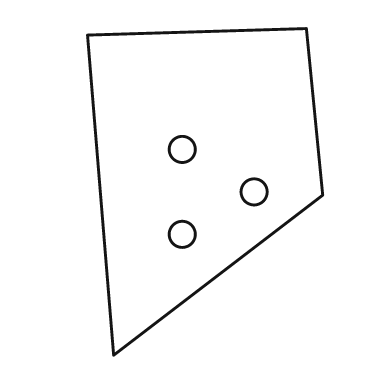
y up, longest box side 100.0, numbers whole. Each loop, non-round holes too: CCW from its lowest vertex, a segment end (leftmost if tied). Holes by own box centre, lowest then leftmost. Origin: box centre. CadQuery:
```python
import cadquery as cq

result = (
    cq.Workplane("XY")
    .moveTo(-28.0, -50.0)
    .lineTo(36.0, -1.0)
    .lineTo(31.0, 50.0)
    .lineTo(-36.0, 48.0)
    .close()
    .moveTo(-7.0, -13.0)
    .circle(4.0)
    .moveTo(15.0, 0.0)
    .circle(4.0)
    .moveTo(-7.0, 13.0)
    .circle(4.0)
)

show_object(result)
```